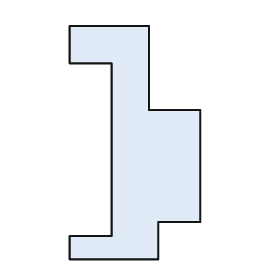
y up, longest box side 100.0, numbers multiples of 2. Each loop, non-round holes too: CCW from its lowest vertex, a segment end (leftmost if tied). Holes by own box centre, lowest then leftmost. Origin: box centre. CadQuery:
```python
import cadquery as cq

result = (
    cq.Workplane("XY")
    .moveTo(-28.0, -50.0)
    .lineTo(10.0, -50.0)
    .lineTo(10.0, -34.0)
    .lineTo(28.0, -34.0)
    .lineTo(28.0, 14.0)
    .lineTo(6.0, 14.0)
    .lineTo(6.0, 50.0)
    .lineTo(-28.0, 50.0)
    .lineTo(-28.0, 34.0)
    .lineTo(-10.0, 34.0)
    .lineTo(-10.0, -40.0)
    .lineTo(-28.0, -40.0)
    .close()
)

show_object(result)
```